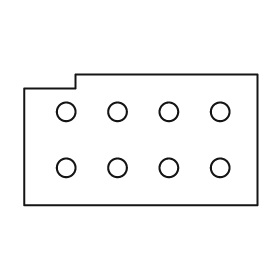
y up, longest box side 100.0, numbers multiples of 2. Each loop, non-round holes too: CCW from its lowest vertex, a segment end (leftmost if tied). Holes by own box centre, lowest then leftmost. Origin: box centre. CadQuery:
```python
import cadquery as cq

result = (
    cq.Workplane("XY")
    .moveTo(-50.0, -28.0)
    .lineTo(50.0, -28.0)
    .lineTo(50.0, 28.0)
    .lineTo(-28.0, 28.0)
    .lineTo(-28.0, 22.0)
    .lineTo(-50.0, 22.0)
    .close()
    .moveTo(-32.0, -12.0)
    .circle(4.0)
    .moveTo(-10.0, -12.0)
    .circle(4.0)
    .moveTo(12.0, -12.0)
    .circle(4.0)
    .moveTo(34.0, -12.0)
    .circle(4.0)
    .moveTo(-32.0, 12.0)
    .circle(4.0)
    .moveTo(-10.0, 12.0)
    .circle(4.0)
    .moveTo(12.0, 12.0)
    .circle(4.0)
    .moveTo(34.0, 12.0)
    .circle(4.0)
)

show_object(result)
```